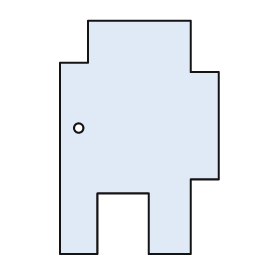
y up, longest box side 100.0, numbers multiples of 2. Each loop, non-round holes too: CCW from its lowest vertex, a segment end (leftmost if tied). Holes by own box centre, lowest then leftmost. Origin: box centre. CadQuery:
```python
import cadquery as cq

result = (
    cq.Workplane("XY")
    .moveTo(-34.0, -50.0)
    .lineTo(-18.0, -50.0)
    .lineTo(-18.0, -24.0)
    .lineTo(4.0, -24.0)
    .lineTo(4.0, -50.0)
    .lineTo(22.0, -50.0)
    .lineTo(22.0, -18.0)
    .lineTo(34.0, -18.0)
    .lineTo(34.0, 28.0)
    .lineTo(22.0, 28.0)
    .lineTo(22.0, 50.0)
    .lineTo(-22.0, 50.0)
    .lineTo(-22.0, 32.0)
    .lineTo(-34.0, 32.0)
    .close()
    .moveTo(-26.0, 4.0)
    .circle(2.0)
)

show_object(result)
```